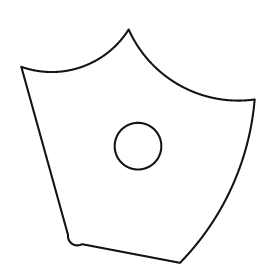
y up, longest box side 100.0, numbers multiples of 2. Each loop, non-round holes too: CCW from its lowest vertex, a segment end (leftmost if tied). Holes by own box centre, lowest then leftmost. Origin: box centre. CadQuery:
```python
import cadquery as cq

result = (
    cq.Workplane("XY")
    .moveTo(18.0, -50.0)
    .threePointArc((40.0, -18.0), (50.0, 20.0))
    .threePointArc((18.0, 26.0), (-4.0, 50.0))
    .threePointArc((-24.0, 34.0), (-50.0, 34.0))
    .lineTo(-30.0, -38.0)
    .threePointArc((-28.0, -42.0), (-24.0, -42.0))
    .close()
    .moveTo(0.0, 0.0)
    .circle(10.0)
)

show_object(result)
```